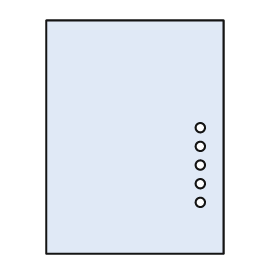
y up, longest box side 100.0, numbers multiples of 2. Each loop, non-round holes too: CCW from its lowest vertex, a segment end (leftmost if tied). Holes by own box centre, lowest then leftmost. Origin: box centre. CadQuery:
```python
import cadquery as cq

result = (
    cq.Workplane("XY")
    .moveTo(-38.0, -50.0)
    .lineTo(38.0, -50.0)
    .lineTo(38.0, 50.0)
    .lineTo(-38.0, 50.0)
    .close()
    .moveTo(28.0, -28.0)
    .circle(2.0)
    .moveTo(28.0, -20.0)
    .circle(2.0)
    .moveTo(28.0, -12.0)
    .circle(2.0)
    .moveTo(28.0, -4.0)
    .circle(2.0)
    .moveTo(28.0, 4.0)
    .circle(2.0)
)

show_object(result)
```